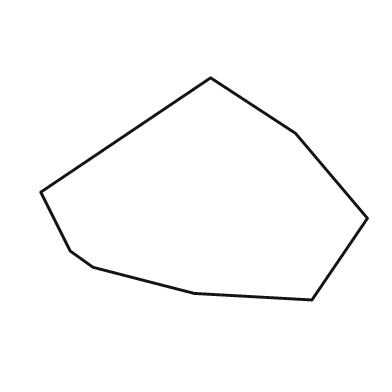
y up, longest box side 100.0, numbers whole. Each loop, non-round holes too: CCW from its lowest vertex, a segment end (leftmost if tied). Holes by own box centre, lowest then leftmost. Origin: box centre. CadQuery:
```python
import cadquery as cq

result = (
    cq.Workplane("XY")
    .moveTo(33.0, -34.0)
    .lineTo(50.0, -9.0)
    .lineTo(28.0, 17.0)
    .lineTo(2.0, 34.0)
    .lineTo(-50.0, -1.0)
    .lineTo(-41.0, -19.0)
    .lineTo(-34.0, -24.0)
    .lineTo(-3.0, -32.0)
    .close()
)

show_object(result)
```